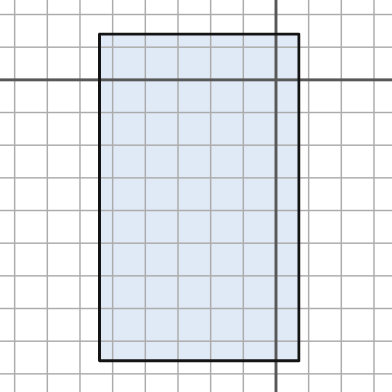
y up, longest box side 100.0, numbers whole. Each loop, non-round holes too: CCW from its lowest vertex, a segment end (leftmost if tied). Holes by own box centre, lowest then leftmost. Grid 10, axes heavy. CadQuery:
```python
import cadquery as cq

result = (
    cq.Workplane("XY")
    .moveTo(-54.0, -86.0)
    .lineTo(7.0, -86.0)
    .lineTo(7.0, 14.0)
    .lineTo(-54.0, 14.0)
    .close()
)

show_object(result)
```